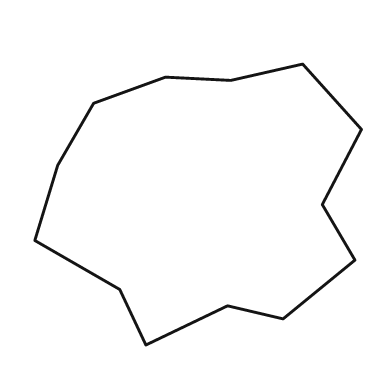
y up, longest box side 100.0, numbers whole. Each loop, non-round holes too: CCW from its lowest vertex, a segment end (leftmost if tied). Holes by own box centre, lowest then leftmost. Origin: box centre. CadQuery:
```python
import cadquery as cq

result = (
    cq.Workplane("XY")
    .moveTo(-16.0, -43.0)
    .lineTo(9.0, -31.0)
    .lineTo(26.0, -35.0)
    .lineTo(48.0, -17.0)
    .lineTo(38.0, 0.0)
    .lineTo(50.0, 23.0)
    .lineTo(32.0, 43.0)
    .lineTo(10.0, 38.0)
    .lineTo(-10.0, 39.0)
    .lineTo(-32.0, 31.0)
    .lineTo(-43.0, 12.0)
    .lineTo(-50.0, -11.0)
    .lineTo(-24.0, -26.0)
    .close()
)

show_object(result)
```